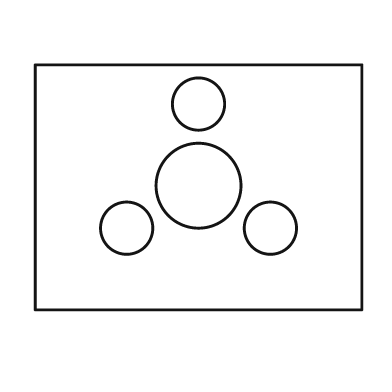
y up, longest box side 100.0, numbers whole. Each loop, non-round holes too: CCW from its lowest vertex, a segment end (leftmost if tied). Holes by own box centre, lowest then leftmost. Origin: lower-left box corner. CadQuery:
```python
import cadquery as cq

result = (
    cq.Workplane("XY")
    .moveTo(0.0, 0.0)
    .lineTo(100.0, 0.0)
    .lineTo(100.0, 75.0)
    .lineTo(0.0, 75.0)
    .close()
    .moveTo(28.0, 25.0)
    .circle(8.0)
    .moveTo(72.0, 25.0)
    .circle(8.0)
    .moveTo(50.0, 38.0)
    .circle(13.0)
    .moveTo(50.0, 63.0)
    .circle(8.0)
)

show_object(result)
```